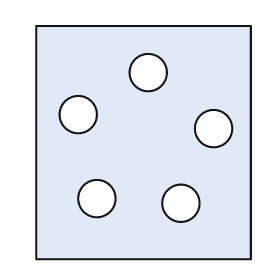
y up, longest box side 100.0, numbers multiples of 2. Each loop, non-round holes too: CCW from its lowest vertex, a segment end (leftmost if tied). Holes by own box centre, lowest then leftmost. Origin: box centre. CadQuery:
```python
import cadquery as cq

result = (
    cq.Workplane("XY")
    .moveTo(-46.0, -50.0)
    .lineTo(46.0, -50.0)
    .lineTo(46.0, 50.0)
    .lineTo(-46.0, 50.0)
    .close()
    .moveTo(16.0, -26.0)
    .circle(8.0)
    .moveTo(-20.0, -24.0)
    .circle(8.0)
    .moveTo(30.0, 6.0)
    .circle(8.0)
    .moveTo(-28.0, 12.0)
    .circle(8.0)
    .moveTo(2.0, 30.0)
    .circle(8.0)
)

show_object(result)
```